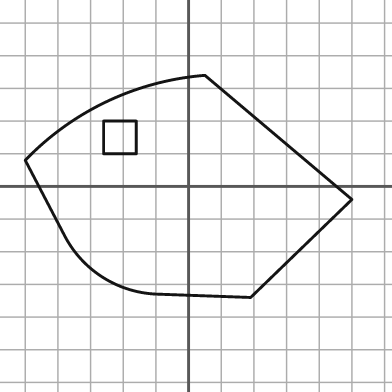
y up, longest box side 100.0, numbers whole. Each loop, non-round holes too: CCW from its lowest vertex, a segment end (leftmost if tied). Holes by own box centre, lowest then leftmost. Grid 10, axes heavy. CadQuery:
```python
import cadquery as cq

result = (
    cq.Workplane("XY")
    .moveTo(19.0, -34.0)
    .lineTo(50.0, -4.0)
    .lineTo(5.0, 34.0)
    .threePointArc((-25.0, 26.0), (-50.0, 8.0))
    .lineTo(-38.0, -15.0)
    .threePointArc((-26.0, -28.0), (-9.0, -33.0))
    .close()
    .moveTo(-26.0, 10.0)
    .lineTo(-16.0, 10.0)
    .lineTo(-16.0, 20.0)
    .lineTo(-26.0, 20.0)
    .close()
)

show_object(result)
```